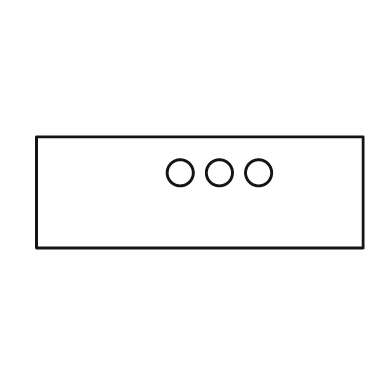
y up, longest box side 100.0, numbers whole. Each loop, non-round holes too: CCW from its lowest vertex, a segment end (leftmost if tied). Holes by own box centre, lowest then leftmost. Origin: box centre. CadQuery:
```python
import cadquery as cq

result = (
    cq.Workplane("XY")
    .moveTo(-50.0, -17.0)
    .lineTo(50.0, -17.0)
    .lineTo(50.0, 17.0)
    .lineTo(-50.0, 17.0)
    .close()
    .moveTo(-6.0, 6.0)
    .circle(4.0)
    .moveTo(6.0, 6.0)
    .circle(4.0)
    .moveTo(18.0, 6.0)
    .circle(4.0)
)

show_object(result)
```